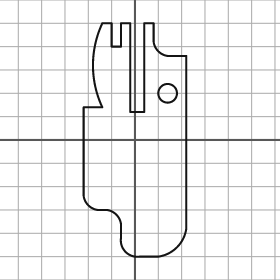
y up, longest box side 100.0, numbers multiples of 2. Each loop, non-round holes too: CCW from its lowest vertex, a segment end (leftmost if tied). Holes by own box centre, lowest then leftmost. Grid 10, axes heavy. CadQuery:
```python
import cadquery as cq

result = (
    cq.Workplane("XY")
    .moveTo(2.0, -50.0)
    .lineTo(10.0, -50.0)
    .threePointArc((18.0, -46.0), (22.0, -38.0))
    .lineTo(22.0, 36.0)
    .lineTo(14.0, 36.0)
    .threePointArc((10.0, 38.0), (8.0, 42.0))
    .lineTo(8.0, 50.0)
    .lineTo(4.0, 50.0)
    .lineTo(4.0, 12.0)
    .lineTo(-2.0, 12.0)
    .lineTo(-2.0, 50.0)
    .lineTo(-6.0, 50.0)
    .lineTo(-6.0, 40.0)
    .lineTo(-10.0, 40.0)
    .lineTo(-10.0, 50.0)
    .lineTo(-14.0, 50.0)
    .threePointArc((-18.0, 32.0), (-14.0, 14.0))
    .lineTo(-22.0, 14.0)
    .lineTo(-22.0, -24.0)
    .threePointArc((-20.0, -28.0), (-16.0, -30.0))
    .lineTo(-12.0, -30.0)
    .threePointArc((-8.0, -32.0), (-6.0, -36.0))
    .lineTo(-6.0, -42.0)
    .threePointArc((-4.0, -48.0), (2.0, -50.0))
    .close()
    .moveTo(14.0, 20.0)
    .circle(4.0)
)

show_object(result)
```